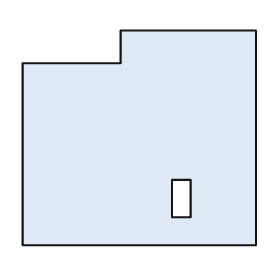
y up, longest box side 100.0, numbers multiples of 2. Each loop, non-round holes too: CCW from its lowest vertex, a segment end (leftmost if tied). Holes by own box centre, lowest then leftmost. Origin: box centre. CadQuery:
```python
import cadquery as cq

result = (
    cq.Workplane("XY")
    .moveTo(-50.0, -46.0)
    .lineTo(50.0, -46.0)
    .lineTo(50.0, 46.0)
    .lineTo(-8.0, 46.0)
    .lineTo(-8.0, 32.0)
    .lineTo(-50.0, 32.0)
    .close()
    .moveTo(14.0, -34.0)
    .lineTo(22.0, -34.0)
    .lineTo(22.0, -18.0)
    .lineTo(14.0, -18.0)
    .close()
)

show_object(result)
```